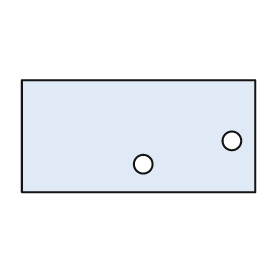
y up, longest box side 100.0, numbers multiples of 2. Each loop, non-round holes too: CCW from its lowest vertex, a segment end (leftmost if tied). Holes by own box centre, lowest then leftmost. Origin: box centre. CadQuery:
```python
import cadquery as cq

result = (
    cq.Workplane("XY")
    .moveTo(-50.0, -24.0)
    .lineTo(50.0, -24.0)
    .lineTo(50.0, 24.0)
    .lineTo(-50.0, 24.0)
    .close()
    .moveTo(2.0, -12.0)
    .circle(4.0)
    .moveTo(40.0, -2.0)
    .circle(4.0)
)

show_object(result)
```